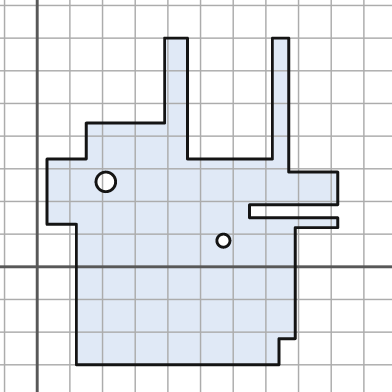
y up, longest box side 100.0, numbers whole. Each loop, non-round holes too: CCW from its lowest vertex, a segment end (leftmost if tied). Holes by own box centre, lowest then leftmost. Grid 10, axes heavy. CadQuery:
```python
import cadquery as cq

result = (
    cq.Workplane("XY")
    .moveTo(12.0, -30.0)
    .lineTo(74.0, -30.0)
    .lineTo(74.0, -22.0)
    .lineTo(79.0, -22.0)
    .lineTo(79.0, 12.0)
    .lineTo(92.0, 12.0)
    .lineTo(92.0, 15.0)
    .lineTo(65.0, 15.0)
    .lineTo(65.0, 19.0)
    .lineTo(92.0, 19.0)
    .lineTo(92.0, 29.0)
    .lineTo(77.0, 29.0)
    .lineTo(77.0, 70.0)
    .lineTo(72.0, 70.0)
    .lineTo(72.0, 33.0)
    .lineTo(46.0, 33.0)
    .lineTo(46.0, 70.0)
    .lineTo(39.0, 70.0)
    .lineTo(39.0, 44.0)
    .lineTo(15.0, 44.0)
    .lineTo(15.0, 33.0)
    .lineTo(3.0, 33.0)
    .lineTo(3.0, 13.0)
    .lineTo(12.0, 13.0)
    .close()
    .moveTo(57.0, 8.0)
    .circle(2.0)
    .moveTo(21.0, 26.0)
    .circle(3.0)
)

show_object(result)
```